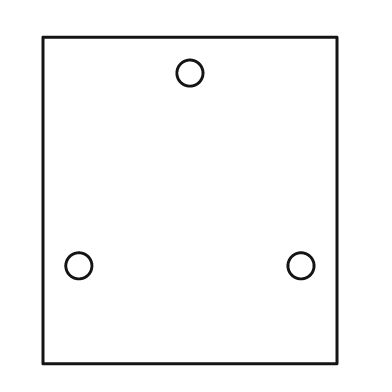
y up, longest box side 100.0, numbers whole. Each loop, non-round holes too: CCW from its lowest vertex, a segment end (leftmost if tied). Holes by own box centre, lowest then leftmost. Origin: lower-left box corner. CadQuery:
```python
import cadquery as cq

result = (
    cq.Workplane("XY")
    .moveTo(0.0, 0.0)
    .lineTo(90.0, 0.0)
    .lineTo(90.0, 100.0)
    .lineTo(0.0, 100.0)
    .close()
    .moveTo(11.0, 30.0)
    .circle(4.0)
    .moveTo(79.0, 30.0)
    .circle(4.0)
    .moveTo(45.0, 89.0)
    .circle(4.0)
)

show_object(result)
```